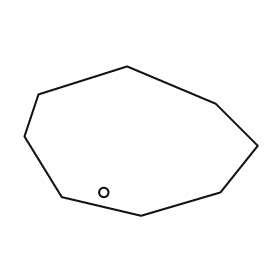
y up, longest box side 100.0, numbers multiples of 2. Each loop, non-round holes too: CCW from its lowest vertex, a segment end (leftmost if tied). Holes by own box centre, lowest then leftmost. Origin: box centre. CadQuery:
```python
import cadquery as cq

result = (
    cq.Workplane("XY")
    .moveTo(0.0, -32.0)
    .lineTo(34.0, -22.0)
    .lineTo(50.0, -2.0)
    .lineTo(32.0, 16.0)
    .lineTo(-6.0, 32.0)
    .lineTo(-44.0, 20.0)
    .lineTo(-50.0, 2.0)
    .lineTo(-34.0, -24.0)
    .close()
    .moveTo(-16.0, -22.0)
    .circle(2.0)
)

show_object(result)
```